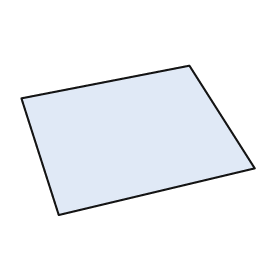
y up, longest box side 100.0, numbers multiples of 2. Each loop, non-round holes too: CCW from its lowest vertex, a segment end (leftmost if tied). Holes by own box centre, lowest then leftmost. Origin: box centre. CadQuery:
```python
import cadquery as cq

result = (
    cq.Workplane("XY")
    .moveTo(-34.0, -32.0)
    .lineTo(50.0, -12.0)
    .lineTo(22.0, 32.0)
    .lineTo(-50.0, 18.0)
    .close()
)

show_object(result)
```